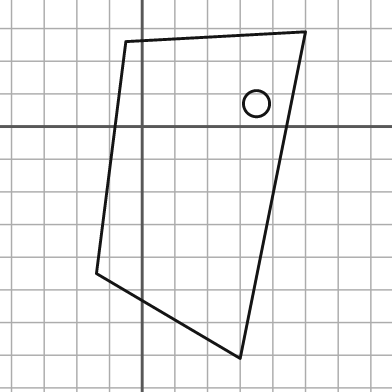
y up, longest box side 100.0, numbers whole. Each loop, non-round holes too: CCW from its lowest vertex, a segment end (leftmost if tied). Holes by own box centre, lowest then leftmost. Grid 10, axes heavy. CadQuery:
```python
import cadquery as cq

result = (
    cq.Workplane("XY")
    .moveTo(30.0, -71.0)
    .lineTo(50.0, 29.0)
    .lineTo(-5.0, 26.0)
    .lineTo(-14.0, -45.0)
    .close()
    .moveTo(35.0, 7.0)
    .circle(4.0)
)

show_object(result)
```